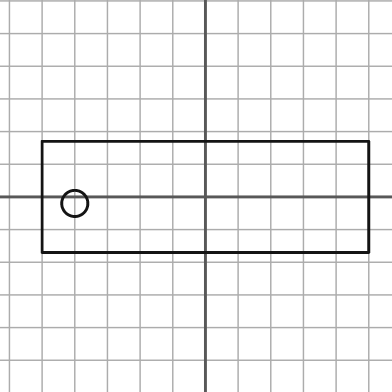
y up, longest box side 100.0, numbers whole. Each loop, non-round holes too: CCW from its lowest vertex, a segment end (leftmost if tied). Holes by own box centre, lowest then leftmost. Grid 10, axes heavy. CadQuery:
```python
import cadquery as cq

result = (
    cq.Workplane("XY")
    .moveTo(-50.0, -17.0)
    .lineTo(50.0, -17.0)
    .lineTo(50.0, 17.0)
    .lineTo(-50.0, 17.0)
    .close()
    .moveTo(-40.0, -2.0)
    .circle(4.0)
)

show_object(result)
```